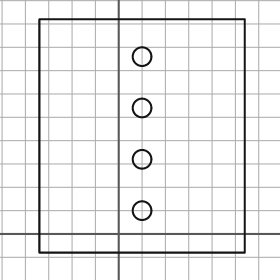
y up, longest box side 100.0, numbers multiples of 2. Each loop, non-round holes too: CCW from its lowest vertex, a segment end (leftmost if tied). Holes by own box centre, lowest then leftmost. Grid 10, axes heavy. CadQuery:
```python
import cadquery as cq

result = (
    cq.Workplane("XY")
    .moveTo(-34.0, -8.0)
    .lineTo(54.0, -8.0)
    .lineTo(54.0, 92.0)
    .lineTo(-34.0, 92.0)
    .close()
    .moveTo(10.0, 10.0)
    .circle(4.0)
    .moveTo(10.0, 32.0)
    .circle(4.0)
    .moveTo(10.0, 54.0)
    .circle(4.0)
    .moveTo(10.0, 76.0)
    .circle(4.0)
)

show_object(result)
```